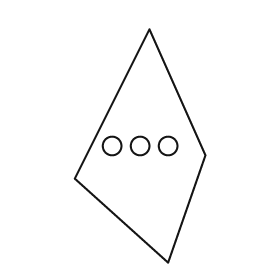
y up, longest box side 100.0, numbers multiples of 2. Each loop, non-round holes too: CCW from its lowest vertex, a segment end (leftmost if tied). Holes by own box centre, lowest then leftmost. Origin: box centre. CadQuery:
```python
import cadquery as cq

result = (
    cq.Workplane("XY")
    .moveTo(12.0, -50.0)
    .lineTo(28.0, -4.0)
    .lineTo(4.0, 50.0)
    .lineTo(-28.0, -14.0)
    .close()
    .moveTo(-12.0, 0.0)
    .circle(4.0)
    .moveTo(0.0, 0.0)
    .circle(4.0)
    .moveTo(12.0, 0.0)
    .circle(4.0)
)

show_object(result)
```